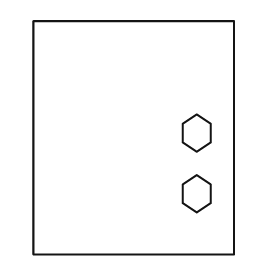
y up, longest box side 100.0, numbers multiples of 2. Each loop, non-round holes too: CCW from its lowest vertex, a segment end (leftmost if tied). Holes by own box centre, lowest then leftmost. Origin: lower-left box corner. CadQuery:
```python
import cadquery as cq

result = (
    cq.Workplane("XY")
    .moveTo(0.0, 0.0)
    .lineTo(86.0, 0.0)
    .lineTo(86.0, 100.0)
    .lineTo(0.0, 100.0)
    .close()
    .moveTo(70.0, 18.0)
    .lineTo(76.0, 22.0)
    .lineTo(76.0, 30.0)
    .lineTo(70.0, 34.0)
    .lineTo(64.0, 30.0)
    .lineTo(64.0, 22.0)
    .close()
    .moveTo(70.0, 44.0)
    .lineTo(76.0, 48.0)
    .lineTo(76.0, 56.0)
    .lineTo(70.0, 60.0)
    .lineTo(64.0, 56.0)
    .lineTo(64.0, 48.0)
    .close()
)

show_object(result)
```